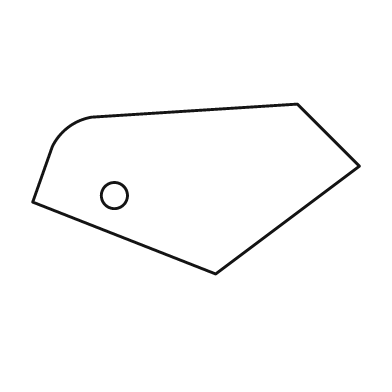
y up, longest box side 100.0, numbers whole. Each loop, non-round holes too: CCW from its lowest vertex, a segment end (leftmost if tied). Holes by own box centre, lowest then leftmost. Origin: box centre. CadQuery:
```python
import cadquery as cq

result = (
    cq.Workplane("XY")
    .moveTo(6.0, -26.0)
    .lineTo(50.0, 7.0)
    .lineTo(31.0, 26.0)
    .lineTo(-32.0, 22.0)
    .threePointArc((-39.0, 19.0), (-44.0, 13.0))
    .lineTo(-50.0, -4.0)
    .close()
    .moveTo(-25.0, -2.0)
    .circle(4.0)
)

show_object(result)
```